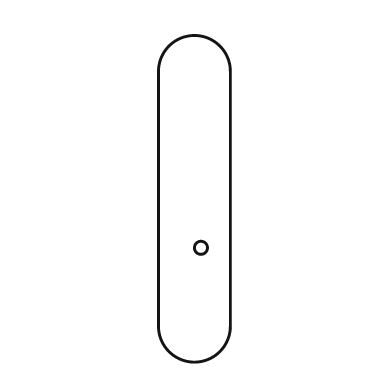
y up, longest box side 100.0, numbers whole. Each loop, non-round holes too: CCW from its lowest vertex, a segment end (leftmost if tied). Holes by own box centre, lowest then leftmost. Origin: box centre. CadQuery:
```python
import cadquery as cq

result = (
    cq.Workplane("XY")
    .moveTo(-11.0, -39.0)
    .threePointArc((0.0, -50.0), (11.0, -39.0))
    .lineTo(11.0, 39.0)
    .threePointArc((0.0, 50.0), (-11.0, 39.0))
    .close()
    .moveTo(2.0, -15.0)
    .circle(2.0)
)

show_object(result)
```